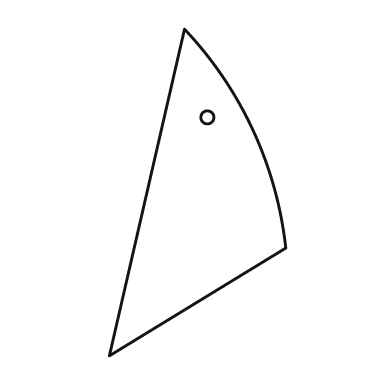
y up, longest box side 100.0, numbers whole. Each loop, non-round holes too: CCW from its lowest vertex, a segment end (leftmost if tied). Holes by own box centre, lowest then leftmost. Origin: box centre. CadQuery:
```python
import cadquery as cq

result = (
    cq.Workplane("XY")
    .moveTo(-27.0, -50.0)
    .lineTo(27.0, -17.0)
    .threePointArc((17.0, 19.0), (-4.0, 50.0))
    .close()
    .moveTo(3.0, 23.0)
    .circle(2.0)
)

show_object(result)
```